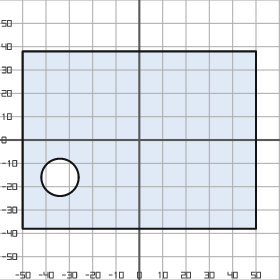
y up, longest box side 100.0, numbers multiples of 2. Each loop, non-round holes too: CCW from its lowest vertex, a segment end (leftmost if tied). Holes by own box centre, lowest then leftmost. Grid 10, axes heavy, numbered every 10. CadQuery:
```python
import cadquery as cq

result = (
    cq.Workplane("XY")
    .moveTo(-50.0, -38.0)
    .lineTo(50.0, -38.0)
    .lineTo(50.0, 38.0)
    .lineTo(-50.0, 38.0)
    .close()
    .moveTo(-34.0, -16.0)
    .circle(8.0)
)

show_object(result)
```